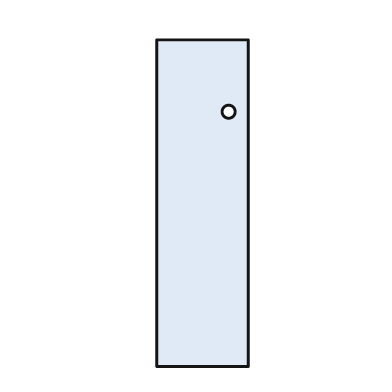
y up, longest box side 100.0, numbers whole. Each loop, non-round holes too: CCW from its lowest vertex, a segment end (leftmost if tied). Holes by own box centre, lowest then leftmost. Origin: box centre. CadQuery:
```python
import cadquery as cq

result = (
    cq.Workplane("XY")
    .moveTo(-14.0, -50.0)
    .lineTo(14.0, -50.0)
    .lineTo(14.0, 50.0)
    .lineTo(-14.0, 50.0)
    .close()
    .moveTo(8.0, 28.0)
    .circle(2.0)
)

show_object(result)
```